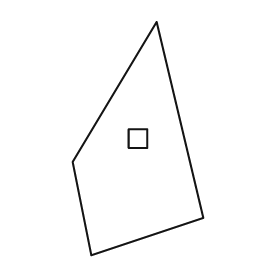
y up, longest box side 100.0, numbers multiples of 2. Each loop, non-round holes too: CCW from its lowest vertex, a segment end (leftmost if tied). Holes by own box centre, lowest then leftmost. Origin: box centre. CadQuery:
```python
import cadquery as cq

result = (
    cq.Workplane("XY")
    .moveTo(-20.0, -50.0)
    .lineTo(28.0, -34.0)
    .lineTo(8.0, 50.0)
    .lineTo(-28.0, -10.0)
    .close()
    .moveTo(-4.0, -4.0)
    .lineTo(4.0, -4.0)
    .lineTo(4.0, 4.0)
    .lineTo(-4.0, 4.0)
    .close()
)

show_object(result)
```